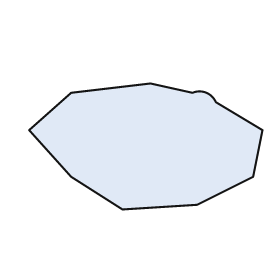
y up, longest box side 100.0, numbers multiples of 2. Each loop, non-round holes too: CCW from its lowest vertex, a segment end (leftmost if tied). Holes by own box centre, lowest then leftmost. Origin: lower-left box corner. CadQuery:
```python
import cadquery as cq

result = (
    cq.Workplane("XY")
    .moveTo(40.0, 0.0)
    .lineTo(72.0, 2.0)
    .lineTo(96.0, 14.0)
    .lineTo(100.0, 34.0)
    .lineTo(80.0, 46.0)
    .threePointArc((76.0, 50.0), (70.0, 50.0))
    .lineTo(52.0, 54.0)
    .lineTo(18.0, 50.0)
    .lineTo(0.0, 34.0)
    .lineTo(18.0, 14.0)
    .close()
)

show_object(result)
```